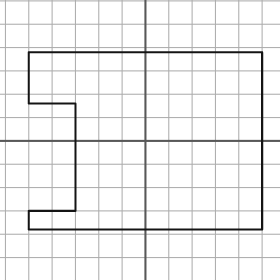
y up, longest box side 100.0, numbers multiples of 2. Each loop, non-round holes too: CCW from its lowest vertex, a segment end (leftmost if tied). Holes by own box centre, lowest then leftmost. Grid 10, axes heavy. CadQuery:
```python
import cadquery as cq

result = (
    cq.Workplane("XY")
    .moveTo(-50.0, -38.0)
    .lineTo(50.0, -38.0)
    .lineTo(50.0, 38.0)
    .lineTo(-50.0, 38.0)
    .lineTo(-50.0, 16.0)
    .lineTo(-30.0, 16.0)
    .lineTo(-30.0, -30.0)
    .lineTo(-50.0, -30.0)
    .close()
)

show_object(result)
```